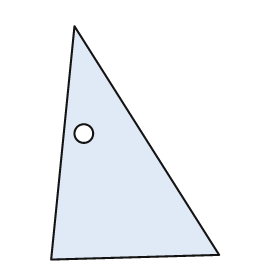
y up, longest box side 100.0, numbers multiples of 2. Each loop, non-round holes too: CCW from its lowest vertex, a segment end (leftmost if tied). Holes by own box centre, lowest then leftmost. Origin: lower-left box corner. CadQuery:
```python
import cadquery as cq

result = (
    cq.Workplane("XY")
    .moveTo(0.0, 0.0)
    .lineTo(72.0, 2.0)
    .lineTo(10.0, 100.0)
    .close()
    .moveTo(14.0, 54.0)
    .circle(4.0)
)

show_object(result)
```